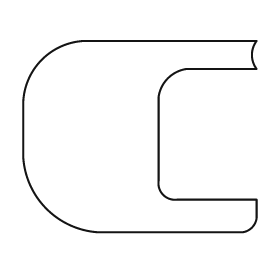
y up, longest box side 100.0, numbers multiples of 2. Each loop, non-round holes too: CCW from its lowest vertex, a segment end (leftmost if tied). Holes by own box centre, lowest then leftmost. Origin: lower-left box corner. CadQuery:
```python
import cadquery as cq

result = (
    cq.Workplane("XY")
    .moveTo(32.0, 0.0)
    .lineTo(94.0, 0.0)
    .threePointArc((98.0, 2.0), (100.0, 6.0))
    .lineTo(100.0, 14.0)
    .lineTo(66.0, 14.0)
    .threePointArc((60.0, 16.0), (58.0, 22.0))
    .lineTo(58.0, 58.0)
    .threePointArc((62.0, 66.0), (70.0, 70.0))
    .lineTo(100.0, 70.0)
    .threePointArc((98.0, 76.0), (100.0, 82.0))
    .lineTo(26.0, 82.0)
    .threePointArc((8.0, 74.0), (0.0, 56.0))
    .lineTo(0.0, 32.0)
    .threePointArc((10.0, 10.0), (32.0, 0.0))
    .close()
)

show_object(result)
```